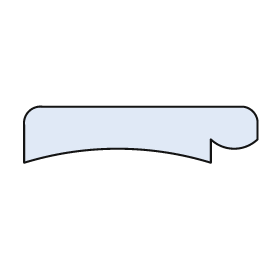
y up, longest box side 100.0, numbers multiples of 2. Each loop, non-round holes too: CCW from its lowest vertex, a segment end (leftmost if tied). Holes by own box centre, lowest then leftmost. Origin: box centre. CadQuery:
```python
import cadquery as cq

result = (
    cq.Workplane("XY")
    .moveTo(-50.0, -12.0)
    .threePointArc((-10.0, -6.0), (30.0, -12.0))
    .lineTo(30.0, -2.0)
    .threePointArc((40.0, -6.0), (50.0, -2.0))
    .lineTo(50.0, 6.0)
    .threePointArc((48.0, 10.0), (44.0, 12.0))
    .lineTo(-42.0, 12.0)
    .threePointArc((-48.0, 10.0), (-50.0, 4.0))
    .close()
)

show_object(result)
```